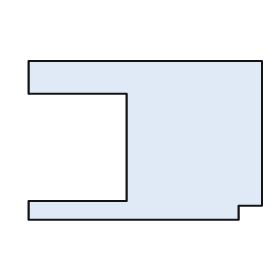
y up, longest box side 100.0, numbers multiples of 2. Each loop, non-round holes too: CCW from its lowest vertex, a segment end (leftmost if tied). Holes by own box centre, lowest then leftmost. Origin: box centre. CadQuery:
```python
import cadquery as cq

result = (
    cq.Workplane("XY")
    .moveTo(-50.0, -34.0)
    .lineTo(40.0, -34.0)
    .lineTo(40.0, -28.0)
    .lineTo(50.0, -28.0)
    .lineTo(50.0, 34.0)
    .lineTo(-50.0, 34.0)
    .lineTo(-50.0, 20.0)
    .lineTo(-8.0, 20.0)
    .lineTo(-8.0, -26.0)
    .lineTo(-50.0, -26.0)
    .close()
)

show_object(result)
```